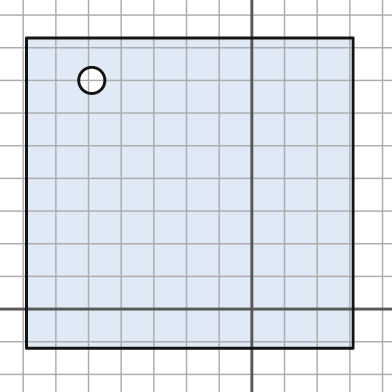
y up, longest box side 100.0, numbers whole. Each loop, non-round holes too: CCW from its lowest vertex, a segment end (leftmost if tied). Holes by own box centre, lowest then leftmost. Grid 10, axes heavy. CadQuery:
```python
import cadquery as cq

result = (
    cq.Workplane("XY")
    .moveTo(-69.0, -12.0)
    .lineTo(31.0, -12.0)
    .lineTo(31.0, 83.0)
    .lineTo(-69.0, 83.0)
    .close()
    .moveTo(-49.0, 70.0)
    .circle(4.0)
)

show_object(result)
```